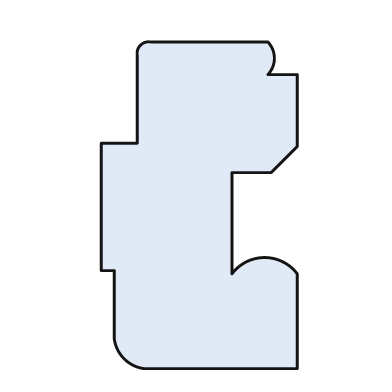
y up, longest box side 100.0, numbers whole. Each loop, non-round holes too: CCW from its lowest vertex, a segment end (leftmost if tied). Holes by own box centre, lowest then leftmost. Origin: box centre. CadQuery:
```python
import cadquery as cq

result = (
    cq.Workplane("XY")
    .moveTo(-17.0, -50.0)
    .lineTo(30.0, -50.0)
    .lineTo(30.0, -21.0)
    .threePointArc((20.0, -16.0), (10.0, -21.0))
    .lineTo(10.0, 10.0)
    .lineTo(22.0, 10.0)
    .lineTo(30.0, 18.0)
    .lineTo(30.0, 40.0)
    .lineTo(21.0, 40.0)
    .threePointArc((23.0, 45.0), (21.0, 50.0))
    .lineTo(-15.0, 50.0)
    .threePointArc((-18.0, 49.0), (-19.0, 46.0))
    .lineTo(-19.0, 19.0)
    .lineTo(-30.0, 19.0)
    .lineTo(-30.0, -20.0)
    .lineTo(-26.0, -20.0)
    .lineTo(-26.0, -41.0)
    .threePointArc((-23.0, -47.0), (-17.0, -50.0))
    .close()
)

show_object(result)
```